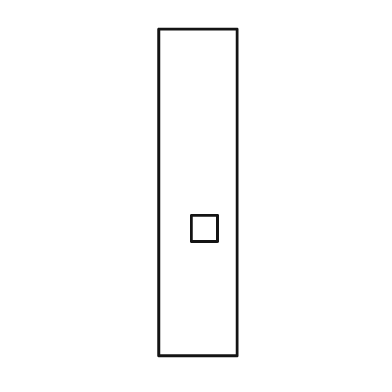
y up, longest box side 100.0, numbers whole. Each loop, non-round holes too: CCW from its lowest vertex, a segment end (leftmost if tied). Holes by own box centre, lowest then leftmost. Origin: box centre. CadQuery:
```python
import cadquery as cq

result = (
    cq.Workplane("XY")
    .moveTo(-12.0, -50.0)
    .lineTo(12.0, -50.0)
    .lineTo(12.0, 50.0)
    .lineTo(-12.0, 50.0)
    .close()
    .moveTo(-2.0, -15.0)
    .lineTo(6.0, -15.0)
    .lineTo(6.0, -7.0)
    .lineTo(-2.0, -7.0)
    .close()
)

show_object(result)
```